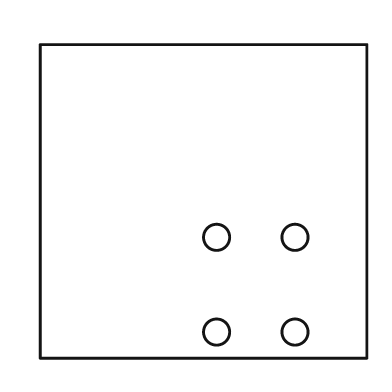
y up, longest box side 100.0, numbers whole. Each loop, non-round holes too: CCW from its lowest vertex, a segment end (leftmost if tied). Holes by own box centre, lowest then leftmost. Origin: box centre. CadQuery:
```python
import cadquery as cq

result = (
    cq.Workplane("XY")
    .moveTo(-50.0, -48.0)
    .lineTo(50.0, -48.0)
    .lineTo(50.0, 48.0)
    .lineTo(-50.0, 48.0)
    .close()
    .moveTo(4.0, -40.0)
    .circle(4.0)
    .moveTo(28.0, -40.0)
    .circle(4.0)
    .moveTo(4.0, -11.0)
    .circle(4.0)
    .moveTo(28.0, -11.0)
    .circle(4.0)
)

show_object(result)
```